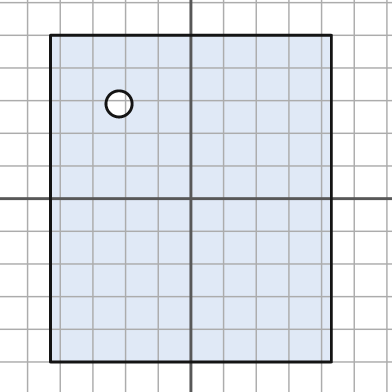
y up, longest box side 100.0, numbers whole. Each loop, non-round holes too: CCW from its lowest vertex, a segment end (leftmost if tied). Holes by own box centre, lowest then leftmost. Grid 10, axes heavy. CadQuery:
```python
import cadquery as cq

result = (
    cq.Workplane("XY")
    .moveTo(-43.0, -50.0)
    .lineTo(43.0, -50.0)
    .lineTo(43.0, 50.0)
    .lineTo(-43.0, 50.0)
    .close()
    .moveTo(-22.0, 29.0)
    .circle(4.0)
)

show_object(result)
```